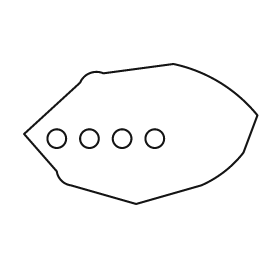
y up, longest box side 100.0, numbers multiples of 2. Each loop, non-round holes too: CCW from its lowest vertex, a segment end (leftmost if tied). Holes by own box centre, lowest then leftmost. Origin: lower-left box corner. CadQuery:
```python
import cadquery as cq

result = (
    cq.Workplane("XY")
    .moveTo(48.0, 0.0)
    .lineTo(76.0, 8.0)
    .threePointArc((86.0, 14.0), (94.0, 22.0))
    .lineTo(100.0, 38.0)
    .threePointArc((84.0, 52.0), (64.0, 60.0))
    .lineTo(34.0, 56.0)
    .threePointArc((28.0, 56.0), (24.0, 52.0))
    .lineTo(0.0, 30.0)
    .lineTo(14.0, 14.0)
    .threePointArc((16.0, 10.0), (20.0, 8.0))
    .close()
    .moveTo(14.0, 28.0)
    .circle(4.0)
    .moveTo(28.0, 28.0)
    .circle(4.0)
    .moveTo(42.0, 28.0)
    .circle(4.0)
    .moveTo(56.0, 28.0)
    .circle(4.0)
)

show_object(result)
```